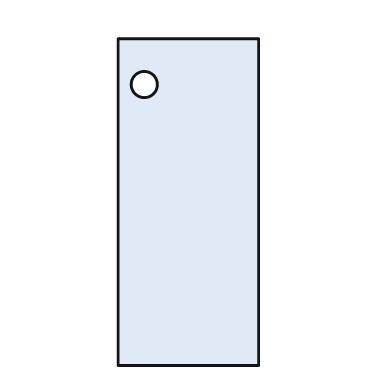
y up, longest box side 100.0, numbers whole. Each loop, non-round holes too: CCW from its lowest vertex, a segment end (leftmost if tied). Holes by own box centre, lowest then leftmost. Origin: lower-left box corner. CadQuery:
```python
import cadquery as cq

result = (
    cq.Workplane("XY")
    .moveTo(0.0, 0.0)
    .lineTo(43.0, 0.0)
    .lineTo(43.0, 100.0)
    .lineTo(0.0, 100.0)
    .close()
    .moveTo(8.0, 86.0)
    .circle(4.0)
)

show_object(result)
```